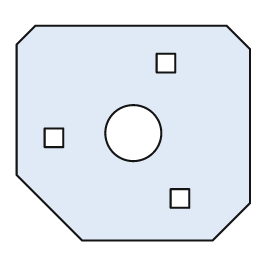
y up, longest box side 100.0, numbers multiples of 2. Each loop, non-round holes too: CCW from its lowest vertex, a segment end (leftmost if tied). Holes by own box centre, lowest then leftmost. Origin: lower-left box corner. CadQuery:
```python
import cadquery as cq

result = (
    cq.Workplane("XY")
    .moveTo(28.0, 0.0)
    .lineTo(84.0, 0.0)
    .lineTo(100.0, 16.0)
    .lineTo(100.0, 82.0)
    .lineTo(90.0, 92.0)
    .lineTo(8.0, 92.0)
    .lineTo(0.0, 84.0)
    .lineTo(0.0, 28.0)
    .close()
    .moveTo(66.0, 14.0)
    .lineTo(74.0, 14.0)
    .lineTo(74.0, 22.0)
    .lineTo(66.0, 22.0)
    .close()
    .moveTo(12.0, 40.0)
    .lineTo(20.0, 40.0)
    .lineTo(20.0, 48.0)
    .lineTo(12.0, 48.0)
    .close()
    .moveTo(50.0, 46.0)
    .circle(12.0)
    .moveTo(60.0, 72.0)
    .lineTo(68.0, 72.0)
    .lineTo(68.0, 80.0)
    .lineTo(60.0, 80.0)
    .close()
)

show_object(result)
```